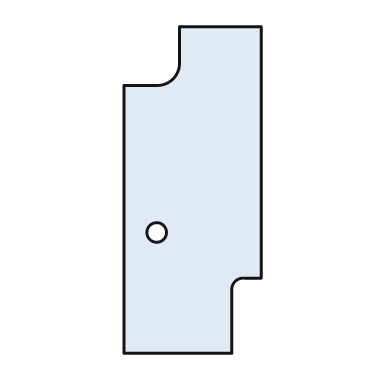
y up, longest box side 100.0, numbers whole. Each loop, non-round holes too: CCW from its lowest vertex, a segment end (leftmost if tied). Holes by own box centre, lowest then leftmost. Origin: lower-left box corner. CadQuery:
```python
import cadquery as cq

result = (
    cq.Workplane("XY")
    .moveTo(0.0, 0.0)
    .lineTo(33.0, 0.0)
    .lineTo(33.0, 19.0)
    .threePointArc((34.0, 22.0), (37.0, 23.0))
    .lineTo(42.0, 23.0)
    .lineTo(42.0, 100.0)
    .lineTo(17.0, 100.0)
    .lineTo(17.0, 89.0)
    .threePointArc((15.0, 84.0), (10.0, 82.0))
    .lineTo(0.0, 82.0)
    .close()
    .moveTo(10.0, 37.0)
    .circle(3.0)
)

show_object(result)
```